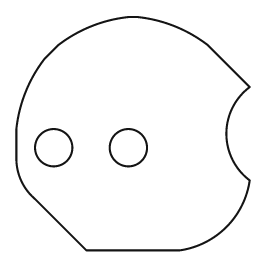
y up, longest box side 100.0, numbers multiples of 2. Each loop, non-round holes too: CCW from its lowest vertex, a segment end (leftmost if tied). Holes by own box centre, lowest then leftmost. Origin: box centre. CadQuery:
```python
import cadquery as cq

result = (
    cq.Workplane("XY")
    .moveTo(-20.0, -50.0)
    .lineTo(20.0, -50.0)
    .threePointArc((40.0, -40.0), (50.0, -20.0))
    .threePointArc((40.0, 0.0), (50.0, 20.0))
    .lineTo(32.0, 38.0)
    .threePointArc((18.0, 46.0), (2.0, 50.0))
    .lineTo(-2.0, 50.0)
    .threePointArc((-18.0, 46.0), (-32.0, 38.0))
    .lineTo(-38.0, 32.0)
    .threePointArc((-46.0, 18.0), (-50.0, 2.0))
    .lineTo(-50.0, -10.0)
    .threePointArc((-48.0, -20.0), (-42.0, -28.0))
    .close()
    .moveTo(-34.0, -6.0)
    .circle(8.0)
    .moveTo(-2.0, -6.0)
    .circle(8.0)
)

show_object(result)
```